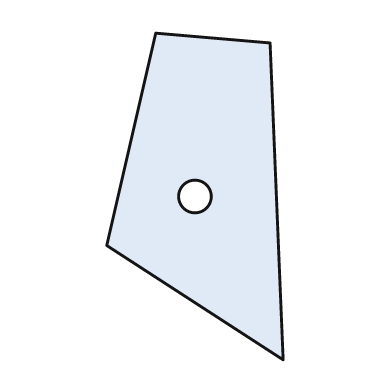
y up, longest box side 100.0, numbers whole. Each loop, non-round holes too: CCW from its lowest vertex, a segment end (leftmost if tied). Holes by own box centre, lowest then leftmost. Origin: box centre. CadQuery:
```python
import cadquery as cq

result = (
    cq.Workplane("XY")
    .moveTo(27.0, -50.0)
    .lineTo(23.0, 47.0)
    .lineTo(-12.0, 50.0)
    .lineTo(-27.0, -15.0)
    .close()
    .moveTo(0.0, 0.0)
    .circle(5.0)
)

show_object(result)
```